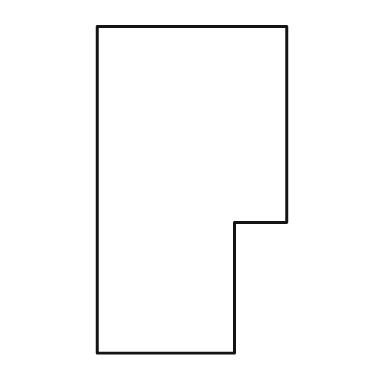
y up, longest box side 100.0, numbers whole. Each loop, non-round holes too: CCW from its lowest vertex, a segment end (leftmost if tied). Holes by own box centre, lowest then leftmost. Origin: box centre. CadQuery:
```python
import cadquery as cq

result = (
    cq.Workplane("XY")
    .moveTo(-29.0, -50.0)
    .lineTo(13.0, -50.0)
    .lineTo(13.0, -10.0)
    .lineTo(29.0, -10.0)
    .lineTo(29.0, 50.0)
    .lineTo(-29.0, 50.0)
    .close()
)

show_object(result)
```